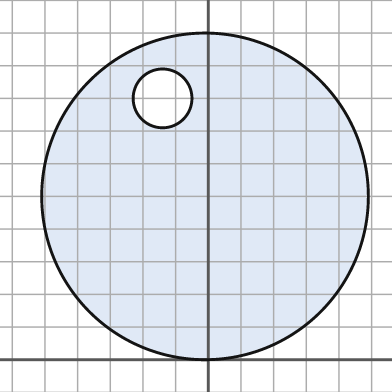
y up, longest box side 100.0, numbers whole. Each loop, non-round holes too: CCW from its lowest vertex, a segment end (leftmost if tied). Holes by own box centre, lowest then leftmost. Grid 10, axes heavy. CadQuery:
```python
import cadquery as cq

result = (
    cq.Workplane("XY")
    .moveTo(-1.0, 50.0)
    .circle(50.0)
    .moveTo(-14.0, 80.0)
    .circle(9.0)
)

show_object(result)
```